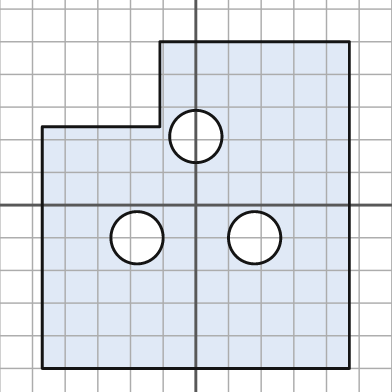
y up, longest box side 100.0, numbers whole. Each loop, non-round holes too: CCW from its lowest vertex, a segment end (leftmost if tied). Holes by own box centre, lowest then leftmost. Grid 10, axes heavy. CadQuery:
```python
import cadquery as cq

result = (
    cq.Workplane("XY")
    .moveTo(-47.0, -50.0)
    .lineTo(47.0, -50.0)
    .lineTo(47.0, 50.0)
    .lineTo(-11.0, 50.0)
    .lineTo(-11.0, 24.0)
    .lineTo(-47.0, 24.0)
    .close()
    .moveTo(-18.0, -10.0)
    .circle(8.0)
    .moveTo(18.0, -10.0)
    .circle(8.0)
    .moveTo(0.0, 21.0)
    .circle(8.0)
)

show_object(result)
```